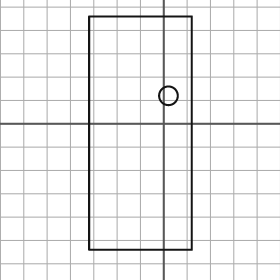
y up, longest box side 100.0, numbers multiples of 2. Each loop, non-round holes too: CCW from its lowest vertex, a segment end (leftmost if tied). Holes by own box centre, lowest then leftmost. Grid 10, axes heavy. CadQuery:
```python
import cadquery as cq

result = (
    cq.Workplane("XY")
    .moveTo(-32.0, -54.0)
    .lineTo(12.0, -54.0)
    .lineTo(12.0, 46.0)
    .lineTo(-32.0, 46.0)
    .close()
    .moveTo(2.0, 12.0)
    .circle(4.0)
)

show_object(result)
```